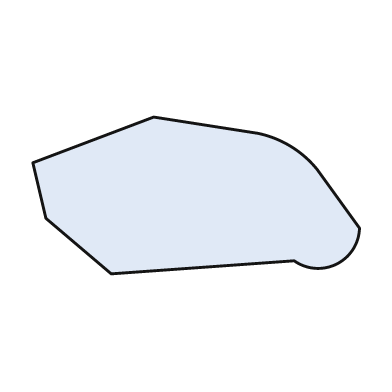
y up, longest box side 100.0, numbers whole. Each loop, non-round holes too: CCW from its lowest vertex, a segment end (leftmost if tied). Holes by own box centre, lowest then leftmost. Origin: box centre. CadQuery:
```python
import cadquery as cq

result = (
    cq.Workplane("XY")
    .moveTo(-26.0, -24.0)
    .lineTo(30.0, -20.0)
    .threePointArc((43.0, -21.0), (50.0, -10.0))
    .lineTo(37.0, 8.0)
    .threePointArc((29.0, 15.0), (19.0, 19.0))
    .lineTo(-13.0, 24.0)
    .lineTo(-50.0, 10.0)
    .lineTo(-46.0, -7.0)
    .close()
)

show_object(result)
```